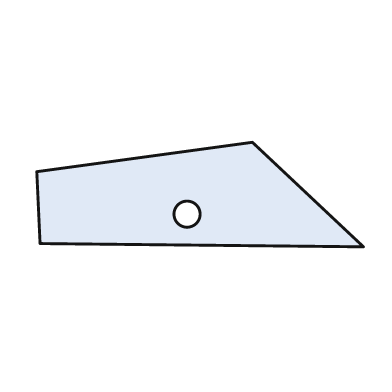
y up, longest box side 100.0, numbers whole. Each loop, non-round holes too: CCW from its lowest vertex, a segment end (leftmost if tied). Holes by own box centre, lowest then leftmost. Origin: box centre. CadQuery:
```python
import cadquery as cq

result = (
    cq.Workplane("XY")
    .moveTo(50.0, -16.0)
    .lineTo(16.0, 16.0)
    .lineTo(-50.0, 7.0)
    .lineTo(-49.0, -15.0)
    .close()
    .moveTo(-4.0, -6.0)
    .circle(4.0)
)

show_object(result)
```